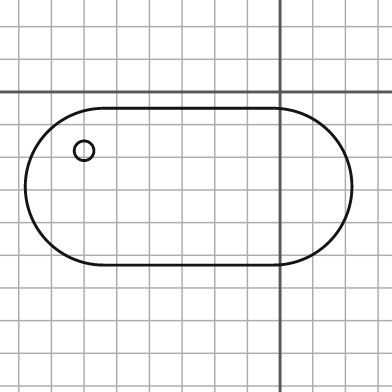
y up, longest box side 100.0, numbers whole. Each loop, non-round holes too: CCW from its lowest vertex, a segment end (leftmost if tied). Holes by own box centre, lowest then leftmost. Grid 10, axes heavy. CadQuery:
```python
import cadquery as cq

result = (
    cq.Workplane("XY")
    .moveTo(-54.0, -53.0)
    .lineTo(-2.0, -53.0)
    .threePointArc((22.0, -29.0), (-2.0, -5.0))
    .lineTo(-54.0, -5.0)
    .threePointArc((-78.0, -29.0), (-54.0, -53.0))
    .close()
    .moveTo(-60.0, -18.0)
    .circle(3.0)
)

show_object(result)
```